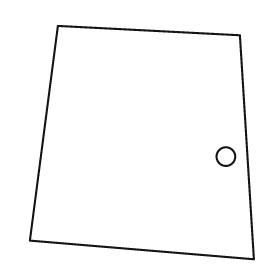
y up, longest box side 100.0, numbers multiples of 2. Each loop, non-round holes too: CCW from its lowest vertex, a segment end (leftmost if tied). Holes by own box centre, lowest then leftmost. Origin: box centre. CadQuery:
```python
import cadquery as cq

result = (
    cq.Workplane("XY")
    .moveTo(48.0, -50.0)
    .lineTo(42.0, 46.0)
    .lineTo(-36.0, 50.0)
    .lineTo(-48.0, -42.0)
    .close()
    .moveTo(36.0, -6.0)
    .circle(4.0)
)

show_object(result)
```